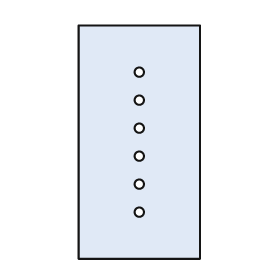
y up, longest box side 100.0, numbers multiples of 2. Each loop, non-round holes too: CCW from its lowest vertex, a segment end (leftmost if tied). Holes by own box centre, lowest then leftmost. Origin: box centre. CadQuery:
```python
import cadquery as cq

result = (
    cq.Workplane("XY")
    .moveTo(-26.0, -50.0)
    .lineTo(26.0, -50.0)
    .lineTo(26.0, 50.0)
    .lineTo(-26.0, 50.0)
    .close()
    .moveTo(0.0, -30.0)
    .circle(2.0)
    .moveTo(0.0, -18.0)
    .circle(2.0)
    .moveTo(0.0, -6.0)
    .circle(2.0)
    .moveTo(0.0, 6.0)
    .circle(2.0)
    .moveTo(0.0, 18.0)
    .circle(2.0)
    .moveTo(0.0, 30.0)
    .circle(2.0)
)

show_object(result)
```